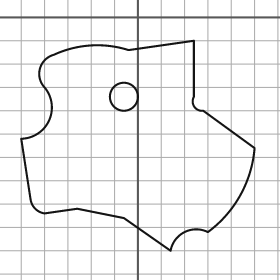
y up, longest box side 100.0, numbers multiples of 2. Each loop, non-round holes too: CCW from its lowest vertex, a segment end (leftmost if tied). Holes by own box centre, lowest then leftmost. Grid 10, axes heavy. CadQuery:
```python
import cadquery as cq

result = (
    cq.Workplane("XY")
    .moveTo(14.0, -100.0)
    .threePointArc((20.0, -92.0), (30.0, -92.0))
    .threePointArc((44.0, -76.0), (50.0, -56.0))
    .lineTo(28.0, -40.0)
    .threePointArc((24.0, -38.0), (24.0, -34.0))
    .lineTo(24.0, -10.0)
    .lineTo(-4.0, -14.0)
    .threePointArc((-20.0, -12.0), (-36.0, -16.0))
    .threePointArc((-42.0, -22.0), (-40.0, -30.0))
    .threePointArc((-38.0, -44.0), (-50.0, -52.0))
    .lineTo(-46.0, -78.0)
    .threePointArc((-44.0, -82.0), (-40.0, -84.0))
    .lineTo(-26.0, -82.0)
    .lineTo(-6.0, -86.0)
    .close()
    .moveTo(-6.0, -34.0)
    .circle(6.0)
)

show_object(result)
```